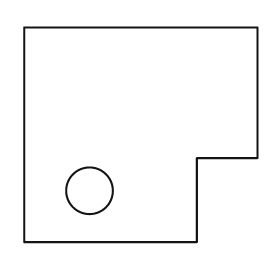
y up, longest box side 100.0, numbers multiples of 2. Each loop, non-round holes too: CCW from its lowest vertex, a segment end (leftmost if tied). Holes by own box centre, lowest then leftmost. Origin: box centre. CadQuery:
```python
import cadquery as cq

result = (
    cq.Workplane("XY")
    .moveTo(-50.0, -46.0)
    .lineTo(24.0, -46.0)
    .lineTo(24.0, -10.0)
    .lineTo(50.0, -10.0)
    .lineTo(50.0, 46.0)
    .lineTo(-50.0, 46.0)
    .close()
    .moveTo(-22.0, -24.0)
    .circle(10.0)
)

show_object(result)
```